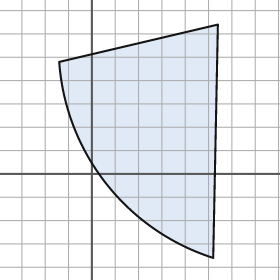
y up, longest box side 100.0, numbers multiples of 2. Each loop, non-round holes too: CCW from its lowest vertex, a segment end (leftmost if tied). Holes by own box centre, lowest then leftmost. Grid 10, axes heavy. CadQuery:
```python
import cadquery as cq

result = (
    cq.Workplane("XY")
    .moveTo(52.0, -36.0)
    .lineTo(54.0, 64.0)
    .lineTo(-14.0, 48.0)
    .threePointArc((6.0, -4.0), (52.0, -36.0))
    .close()
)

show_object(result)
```